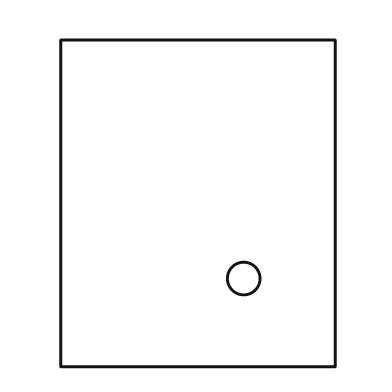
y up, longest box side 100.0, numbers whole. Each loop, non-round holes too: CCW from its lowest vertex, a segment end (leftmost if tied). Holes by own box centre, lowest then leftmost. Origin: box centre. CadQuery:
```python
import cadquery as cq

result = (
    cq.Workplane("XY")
    .moveTo(-42.0, -50.0)
    .lineTo(42.0, -50.0)
    .lineTo(42.0, 50.0)
    .lineTo(-42.0, 50.0)
    .close()
    .moveTo(14.0, -23.0)
    .circle(5.0)
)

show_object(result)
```